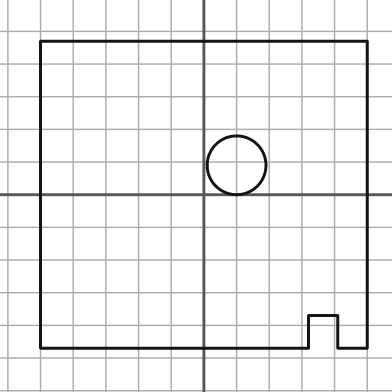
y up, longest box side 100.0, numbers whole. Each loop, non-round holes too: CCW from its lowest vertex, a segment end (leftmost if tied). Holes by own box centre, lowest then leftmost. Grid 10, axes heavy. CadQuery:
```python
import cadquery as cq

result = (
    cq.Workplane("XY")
    .moveTo(-50.0, -47.0)
    .lineTo(32.0, -47.0)
    .lineTo(32.0, -37.0)
    .lineTo(41.0, -37.0)
    .lineTo(41.0, -47.0)
    .lineTo(50.0, -47.0)
    .lineTo(50.0, 47.0)
    .lineTo(-50.0, 47.0)
    .close()
    .moveTo(10.0, 9.0)
    .circle(9.0)
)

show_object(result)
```